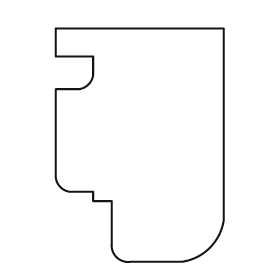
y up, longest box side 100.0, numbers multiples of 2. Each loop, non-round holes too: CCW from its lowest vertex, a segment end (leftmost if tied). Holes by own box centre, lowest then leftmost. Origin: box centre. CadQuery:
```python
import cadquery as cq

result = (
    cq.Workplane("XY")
    .moveTo(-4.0, -50.0)
    .lineTo(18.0, -50.0)
    .threePointArc((30.0, -44.0), (36.0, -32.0))
    .lineTo(36.0, 50.0)
    .lineTo(-36.0, 50.0)
    .lineTo(-36.0, 38.0)
    .lineTo(-20.0, 38.0)
    .lineTo(-20.0, 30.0)
    .threePointArc((-22.0, 26.0), (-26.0, 24.0))
    .lineTo(-36.0, 24.0)
    .lineTo(-36.0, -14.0)
    .threePointArc((-34.0, -18.0), (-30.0, -20.0))
    .lineTo(-20.0, -20.0)
    .lineTo(-20.0, -24.0)
    .lineTo(-12.0, -24.0)
    .lineTo(-12.0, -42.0)
    .threePointArc((-10.0, -48.0), (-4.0, -50.0))
    .close()
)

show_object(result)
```